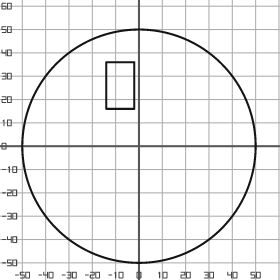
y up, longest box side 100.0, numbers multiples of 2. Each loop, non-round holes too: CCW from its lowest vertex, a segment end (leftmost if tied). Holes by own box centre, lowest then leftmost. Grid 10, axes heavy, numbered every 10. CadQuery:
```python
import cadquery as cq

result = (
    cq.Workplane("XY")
    .moveTo(0.0, 0.0)
    .circle(50.0)
    .moveTo(-14.0, 16.0)
    .lineTo(-2.0, 16.0)
    .lineTo(-2.0, 36.0)
    .lineTo(-14.0, 36.0)
    .close()
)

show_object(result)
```